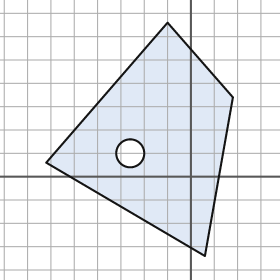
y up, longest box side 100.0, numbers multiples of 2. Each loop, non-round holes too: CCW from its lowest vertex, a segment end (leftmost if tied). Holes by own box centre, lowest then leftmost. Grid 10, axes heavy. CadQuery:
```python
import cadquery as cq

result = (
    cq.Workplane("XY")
    .moveTo(6.0, -34.0)
    .lineTo(18.0, 34.0)
    .lineTo(-10.0, 66.0)
    .lineTo(-62.0, 6.0)
    .close()
    .moveTo(-26.0, 10.0)
    .circle(6.0)
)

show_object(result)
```